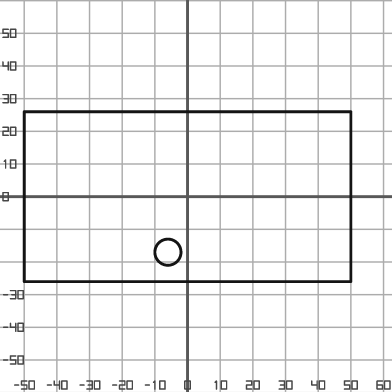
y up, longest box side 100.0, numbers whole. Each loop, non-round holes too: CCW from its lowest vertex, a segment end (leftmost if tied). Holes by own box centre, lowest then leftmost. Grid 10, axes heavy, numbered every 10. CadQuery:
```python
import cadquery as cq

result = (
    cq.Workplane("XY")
    .moveTo(-50.0, -26.0)
    .lineTo(50.0, -26.0)
    .lineTo(50.0, 26.0)
    .lineTo(-50.0, 26.0)
    .close()
    .moveTo(-6.0, -17.0)
    .circle(4.0)
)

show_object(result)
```